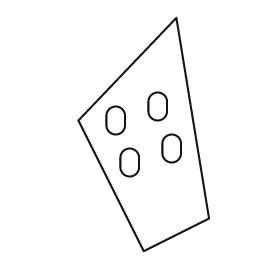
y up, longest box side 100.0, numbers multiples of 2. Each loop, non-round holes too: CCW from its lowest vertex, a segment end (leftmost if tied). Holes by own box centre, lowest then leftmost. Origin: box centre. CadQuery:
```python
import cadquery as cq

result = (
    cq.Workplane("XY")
    .moveTo(0.0, -50.0)
    .lineTo(28.0, -36.0)
    .lineTo(14.0, 50.0)
    .lineTo(-28.0, 6.0)
    .close()
    .moveTo(-10.0, -14.0)
    .threePointArc((-6.0, -18.0), (-2.0, -14.0))
    .lineTo(-2.0, -10.0)
    .threePointArc((-6.0, -6.0), (-10.0, -10.0))
    .close()
    .moveTo(8.0, -8.0)
    .threePointArc((12.0, -12.0), (16.0, -8.0))
    .lineTo(16.0, -4.0)
    .threePointArc((12.0, 0.0), (8.0, -4.0))
    .close()
    .moveTo(-16.0, 4.0)
    .threePointArc((-12.0, 0.0), (-8.0, 4.0))
    .lineTo(-8.0, 8.0)
    .threePointArc((-12.0, 12.0), (-16.0, 8.0))
    .close()
    .moveTo(2.0, 10.0)
    .threePointArc((6.0, 6.0), (10.0, 10.0))
    .lineTo(10.0, 14.0)
    .threePointArc((6.0, 18.0), (2.0, 14.0))
    .close()
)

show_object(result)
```